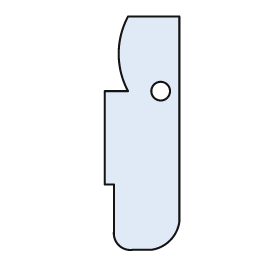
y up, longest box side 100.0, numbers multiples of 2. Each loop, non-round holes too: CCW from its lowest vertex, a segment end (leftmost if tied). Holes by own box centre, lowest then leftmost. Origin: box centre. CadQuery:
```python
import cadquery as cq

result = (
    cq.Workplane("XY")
    .moveTo(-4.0, -50.0)
    .lineTo(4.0, -50.0)
    .threePointArc((12.0, -46.0), (16.0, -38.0))
    .lineTo(16.0, 50.0)
    .lineTo(-6.0, 50.0)
    .threePointArc((-10.0, 34.0), (-6.0, 18.0))
    .lineTo(-16.0, 18.0)
    .lineTo(-16.0, -22.0)
    .lineTo(-12.0, -22.0)
    .lineTo(-12.0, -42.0)
    .threePointArc((-10.0, -48.0), (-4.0, -50.0))
    .close()
    .moveTo(8.0, 18.0)
    .circle(4.0)
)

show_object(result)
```